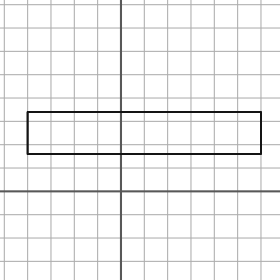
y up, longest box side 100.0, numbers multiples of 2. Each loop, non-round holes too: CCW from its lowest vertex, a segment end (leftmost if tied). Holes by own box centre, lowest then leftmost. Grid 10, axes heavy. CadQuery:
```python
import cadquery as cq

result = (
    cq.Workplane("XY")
    .moveTo(-40.0, 16.0)
    .lineTo(60.0, 16.0)
    .lineTo(60.0, 34.0)
    .lineTo(-40.0, 34.0)
    .close()
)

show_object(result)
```